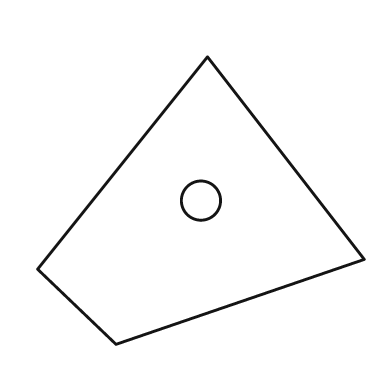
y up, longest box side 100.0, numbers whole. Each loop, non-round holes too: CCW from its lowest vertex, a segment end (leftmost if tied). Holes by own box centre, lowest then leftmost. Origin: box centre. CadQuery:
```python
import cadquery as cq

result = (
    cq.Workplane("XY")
    .moveTo(-26.0, -44.0)
    .lineTo(50.0, -18.0)
    .lineTo(2.0, 44.0)
    .lineTo(-50.0, -21.0)
    .close()
    .moveTo(0.0, 0.0)
    .circle(6.0)
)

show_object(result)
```